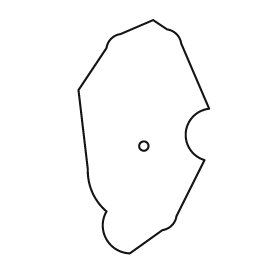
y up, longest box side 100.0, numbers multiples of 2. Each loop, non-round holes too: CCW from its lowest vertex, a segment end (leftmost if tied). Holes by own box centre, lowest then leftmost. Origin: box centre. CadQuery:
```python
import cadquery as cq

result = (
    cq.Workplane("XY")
    .moveTo(-6.0, -50.0)
    .lineTo(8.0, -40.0)
    .threePointArc((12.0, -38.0), (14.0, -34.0))
    .lineTo(26.0, -10.0)
    .threePointArc((18.0, 2.0), (28.0, 12.0))
    .lineTo(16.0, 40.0)
    .threePointArc((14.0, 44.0), (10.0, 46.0))
    .lineTo(4.0, 50.0)
    .lineTo(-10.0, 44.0)
    .threePointArc((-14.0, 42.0), (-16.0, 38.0))
    .lineTo(-28.0, 20.0)
    .lineTo(-24.0, -14.0)
    .threePointArc((-22.0, -24.0), (-16.0, -32.0))
    .threePointArc((-16.0, -44.0), (-6.0, -50.0))
    .close()
    .moveTo(0.0, -4.0)
    .circle(2.0)
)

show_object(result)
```